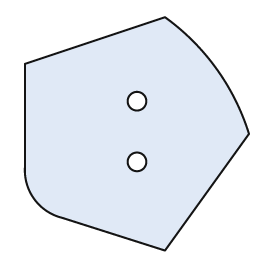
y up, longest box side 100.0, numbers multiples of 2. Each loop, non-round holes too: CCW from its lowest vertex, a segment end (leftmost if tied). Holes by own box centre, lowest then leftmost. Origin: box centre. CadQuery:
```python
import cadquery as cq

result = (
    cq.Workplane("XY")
    .moveTo(12.0, -50.0)
    .lineTo(48.0, 0.0)
    .threePointArc((34.0, 28.0), (12.0, 50.0))
    .lineTo(-48.0, 30.0)
    .lineTo(-48.0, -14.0)
    .threePointArc((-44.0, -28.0), (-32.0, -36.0))
    .close()
    .moveTo(0.0, -12.0)
    .circle(4.0)
    .moveTo(0.0, 14.0)
    .circle(4.0)
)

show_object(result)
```